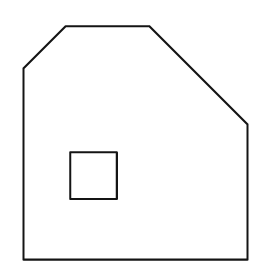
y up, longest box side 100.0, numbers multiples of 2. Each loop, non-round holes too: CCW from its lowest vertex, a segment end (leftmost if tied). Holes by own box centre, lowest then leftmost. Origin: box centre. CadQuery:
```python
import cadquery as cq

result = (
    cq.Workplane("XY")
    .moveTo(-48.0, -50.0)
    .lineTo(48.0, -50.0)
    .lineTo(48.0, 8.0)
    .lineTo(6.0, 50.0)
    .lineTo(-30.0, 50.0)
    .lineTo(-48.0, 32.0)
    .close()
    .moveTo(-28.0, -24.0)
    .lineTo(-8.0, -24.0)
    .lineTo(-8.0, -4.0)
    .lineTo(-28.0, -4.0)
    .close()
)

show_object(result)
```